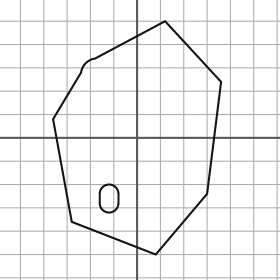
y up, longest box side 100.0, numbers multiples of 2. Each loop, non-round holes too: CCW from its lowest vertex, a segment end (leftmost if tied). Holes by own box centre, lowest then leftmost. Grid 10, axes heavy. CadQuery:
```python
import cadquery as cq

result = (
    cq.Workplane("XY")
    .moveTo(8.0, -50.0)
    .lineTo(30.0, -24.0)
    .lineTo(36.0, 24.0)
    .lineTo(12.0, 50.0)
    .lineTo(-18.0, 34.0)
    .threePointArc((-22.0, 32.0), (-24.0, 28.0))
    .lineTo(-36.0, 8.0)
    .lineTo(-28.0, -36.0)
    .close()
    .moveTo(-16.0, -28.0)
    .threePointArc((-12.0, -32.0), (-8.0, -28.0))
    .lineTo(-8.0, -24.0)
    .threePointArc((-12.0, -20.0), (-16.0, -24.0))
    .close()
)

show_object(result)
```